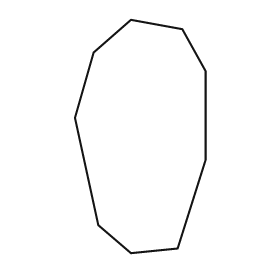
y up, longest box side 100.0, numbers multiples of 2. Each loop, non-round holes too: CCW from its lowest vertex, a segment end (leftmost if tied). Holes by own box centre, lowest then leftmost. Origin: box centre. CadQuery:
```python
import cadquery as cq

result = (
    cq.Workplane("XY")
    .moveTo(-4.0, -50.0)
    .lineTo(16.0, -48.0)
    .lineTo(28.0, -10.0)
    .lineTo(28.0, 28.0)
    .lineTo(18.0, 46.0)
    .lineTo(-4.0, 50.0)
    .lineTo(-20.0, 36.0)
    .lineTo(-28.0, 8.0)
    .lineTo(-18.0, -38.0)
    .close()
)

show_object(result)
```